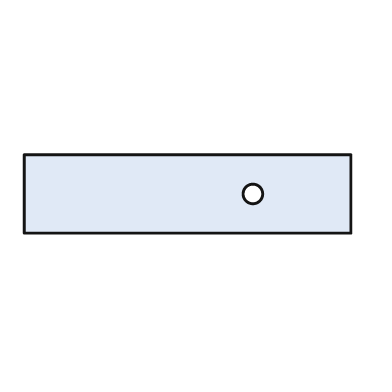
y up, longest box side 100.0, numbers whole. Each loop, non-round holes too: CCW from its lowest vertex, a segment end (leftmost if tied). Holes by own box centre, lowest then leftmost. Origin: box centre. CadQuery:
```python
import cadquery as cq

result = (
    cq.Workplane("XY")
    .moveTo(-50.0, -12.0)
    .lineTo(50.0, -12.0)
    .lineTo(50.0, 12.0)
    .lineTo(-50.0, 12.0)
    .close()
    .moveTo(20.0, 0.0)
    .circle(3.0)
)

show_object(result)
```